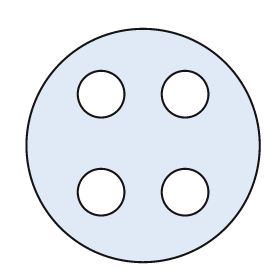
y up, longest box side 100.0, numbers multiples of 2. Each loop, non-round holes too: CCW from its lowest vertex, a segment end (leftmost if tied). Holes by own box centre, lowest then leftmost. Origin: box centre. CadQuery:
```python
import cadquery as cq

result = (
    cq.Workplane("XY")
    .moveTo(0.0, 0.0)
    .circle(50.0)
    .moveTo(-18.0, -20.0)
    .circle(10.0)
    .moveTo(18.0, -20.0)
    .circle(10.0)
    .moveTo(-18.0, 22.0)
    .circle(10.0)
    .moveTo(18.0, 22.0)
    .circle(10.0)
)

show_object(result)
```